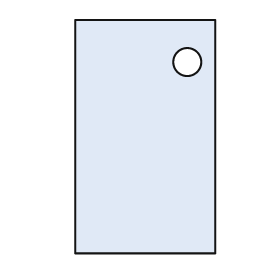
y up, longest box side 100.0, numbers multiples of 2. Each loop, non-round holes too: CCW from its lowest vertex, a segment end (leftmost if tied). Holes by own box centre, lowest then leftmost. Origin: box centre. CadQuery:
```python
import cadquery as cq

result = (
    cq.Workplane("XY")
    .moveTo(-30.0, -50.0)
    .lineTo(30.0, -50.0)
    .lineTo(30.0, 50.0)
    .lineTo(-30.0, 50.0)
    .close()
    .moveTo(18.0, 32.0)
    .circle(6.0)
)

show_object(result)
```